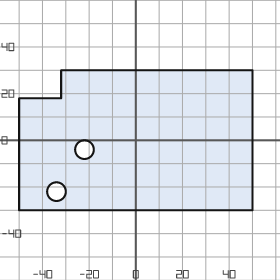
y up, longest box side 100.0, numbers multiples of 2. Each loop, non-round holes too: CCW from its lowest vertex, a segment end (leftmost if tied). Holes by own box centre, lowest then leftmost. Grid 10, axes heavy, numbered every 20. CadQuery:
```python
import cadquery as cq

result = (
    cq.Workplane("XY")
    .moveTo(-50.0, -30.0)
    .lineTo(50.0, -30.0)
    .lineTo(50.0, 30.0)
    .lineTo(-32.0, 30.0)
    .lineTo(-32.0, 18.0)
    .lineTo(-50.0, 18.0)
    .close()
    .moveTo(-34.0, -22.0)
    .circle(4.0)
    .moveTo(-22.0, -4.0)
    .circle(4.0)
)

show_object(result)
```